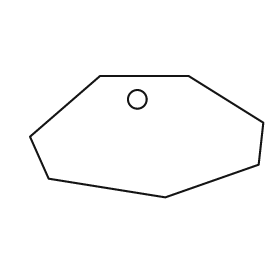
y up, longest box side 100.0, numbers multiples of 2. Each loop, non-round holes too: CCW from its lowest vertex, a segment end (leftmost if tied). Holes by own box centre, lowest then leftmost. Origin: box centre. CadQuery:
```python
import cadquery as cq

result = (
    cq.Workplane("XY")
    .moveTo(8.0, -26.0)
    .lineTo(48.0, -12.0)
    .lineTo(50.0, 6.0)
    .lineTo(18.0, 26.0)
    .lineTo(-20.0, 26.0)
    .lineTo(-50.0, 0.0)
    .lineTo(-42.0, -18.0)
    .close()
    .moveTo(-4.0, 16.0)
    .circle(4.0)
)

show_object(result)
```